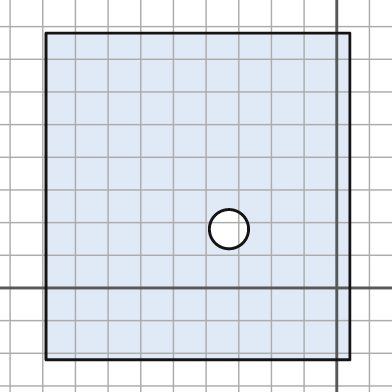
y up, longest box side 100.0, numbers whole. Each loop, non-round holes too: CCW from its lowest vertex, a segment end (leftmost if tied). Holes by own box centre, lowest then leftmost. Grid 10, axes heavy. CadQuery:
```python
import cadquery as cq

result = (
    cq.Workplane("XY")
    .moveTo(-89.0, -22.0)
    .lineTo(4.0, -22.0)
    .lineTo(4.0, 78.0)
    .lineTo(-89.0, 78.0)
    .close()
    .moveTo(-33.0, 18.0)
    .circle(6.0)
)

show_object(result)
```